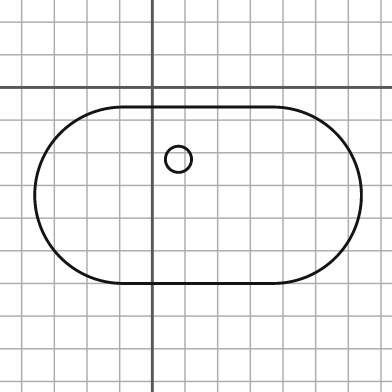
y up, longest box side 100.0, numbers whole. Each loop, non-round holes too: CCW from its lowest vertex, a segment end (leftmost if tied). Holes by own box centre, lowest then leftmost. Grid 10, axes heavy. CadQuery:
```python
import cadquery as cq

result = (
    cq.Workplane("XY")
    .moveTo(-9.0, -60.0)
    .lineTo(37.0, -60.0)
    .threePointArc((64.0, -33.0), (37.0, -6.0))
    .lineTo(-9.0, -6.0)
    .threePointArc((-36.0, -33.0), (-9.0, -60.0))
    .close()
    .moveTo(8.0, -22.0)
    .circle(4.0)
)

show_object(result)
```